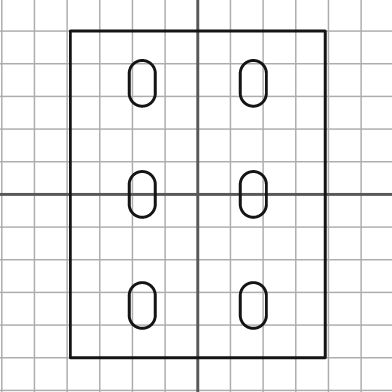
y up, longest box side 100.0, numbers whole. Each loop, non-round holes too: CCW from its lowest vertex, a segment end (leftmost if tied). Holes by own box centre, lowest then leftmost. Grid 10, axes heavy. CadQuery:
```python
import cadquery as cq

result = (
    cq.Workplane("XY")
    .moveTo(-39.0, -50.0)
    .lineTo(39.0, -50.0)
    .lineTo(39.0, 50.0)
    .lineTo(-39.0, 50.0)
    .close()
    .moveTo(-21.0, -37.0)
    .threePointArc((-17.0, -41.0), (-13.0, -37.0))
    .lineTo(-13.0, -31.0)
    .threePointArc((-17.0, -27.0), (-21.0, -31.0))
    .close()
    .moveTo(13.0, -37.0)
    .threePointArc((17.0, -41.0), (21.0, -37.0))
    .lineTo(21.0, -31.0)
    .threePointArc((17.0, -27.0), (13.0, -31.0))
    .close()
    .moveTo(-21.0, -3.0)
    .threePointArc((-17.0, -7.0), (-13.0, -3.0))
    .lineTo(-13.0, 3.0)
    .threePointArc((-17.0, 7.0), (-21.0, 3.0))
    .close()
    .moveTo(13.0, -3.0)
    .threePointArc((17.0, -7.0), (21.0, -3.0))
    .lineTo(21.0, 3.0)
    .threePointArc((17.0, 7.0), (13.0, 3.0))
    .close()
    .moveTo(-21.0, 31.0)
    .threePointArc((-17.0, 27.0), (-13.0, 31.0))
    .lineTo(-13.0, 37.0)
    .threePointArc((-17.0, 41.0), (-21.0, 37.0))
    .close()
    .moveTo(13.0, 31.0)
    .threePointArc((17.0, 27.0), (21.0, 31.0))
    .lineTo(21.0, 37.0)
    .threePointArc((17.0, 41.0), (13.0, 37.0))
    .close()
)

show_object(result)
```